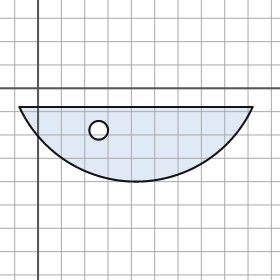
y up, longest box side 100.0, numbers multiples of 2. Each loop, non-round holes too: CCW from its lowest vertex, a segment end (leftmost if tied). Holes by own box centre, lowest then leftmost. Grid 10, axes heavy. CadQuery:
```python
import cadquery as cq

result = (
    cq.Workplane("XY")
    .moveTo(-8.0, -8.0)
    .threePointArc((42.0, -40.0), (92.0, -8.0))
    .close()
    .moveTo(26.0, -18.0)
    .circle(4.0)
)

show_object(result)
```